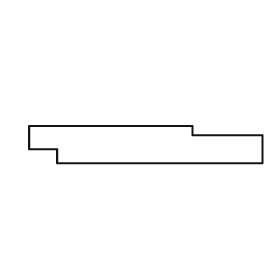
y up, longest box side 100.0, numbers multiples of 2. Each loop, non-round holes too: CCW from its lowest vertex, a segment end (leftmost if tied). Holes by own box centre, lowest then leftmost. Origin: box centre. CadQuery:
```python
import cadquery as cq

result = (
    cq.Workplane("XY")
    .moveTo(-38.0, -8.0)
    .lineTo(50.0, -8.0)
    .lineTo(50.0, 4.0)
    .lineTo(20.0, 4.0)
    .lineTo(20.0, 8.0)
    .lineTo(-50.0, 8.0)
    .lineTo(-50.0, -2.0)
    .lineTo(-38.0, -2.0)
    .close()
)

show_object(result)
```